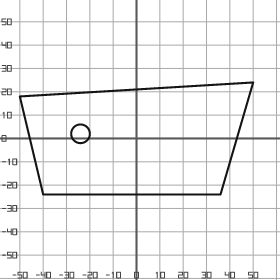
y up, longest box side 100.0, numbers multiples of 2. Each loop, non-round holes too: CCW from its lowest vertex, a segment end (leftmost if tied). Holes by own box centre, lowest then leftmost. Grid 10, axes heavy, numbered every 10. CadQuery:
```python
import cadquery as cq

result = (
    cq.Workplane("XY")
    .moveTo(-40.0, -24.0)
    .lineTo(36.0, -24.0)
    .lineTo(50.0, 24.0)
    .lineTo(-50.0, 18.0)
    .close()
    .moveTo(-24.0, 2.0)
    .circle(4.0)
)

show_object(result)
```